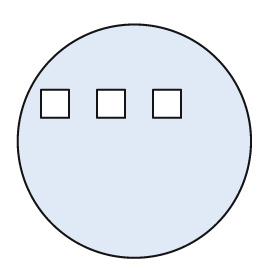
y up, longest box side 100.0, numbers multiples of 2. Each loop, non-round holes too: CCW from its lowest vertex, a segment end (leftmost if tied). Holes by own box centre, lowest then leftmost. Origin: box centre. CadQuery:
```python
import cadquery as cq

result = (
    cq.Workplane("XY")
    .moveTo(0.0, 0.0)
    .circle(50.0)
    .moveTo(-40.0, 10.0)
    .lineTo(-28.0, 10.0)
    .lineTo(-28.0, 22.0)
    .lineTo(-40.0, 22.0)
    .close()
    .moveTo(-16.0, 10.0)
    .lineTo(-4.0, 10.0)
    .lineTo(-4.0, 22.0)
    .lineTo(-16.0, 22.0)
    .close()
    .moveTo(8.0, 10.0)
    .lineTo(20.0, 10.0)
    .lineTo(20.0, 22.0)
    .lineTo(8.0, 22.0)
    .close()
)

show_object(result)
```